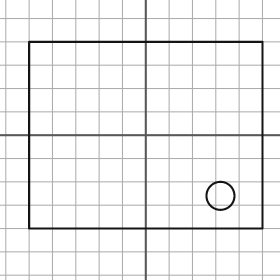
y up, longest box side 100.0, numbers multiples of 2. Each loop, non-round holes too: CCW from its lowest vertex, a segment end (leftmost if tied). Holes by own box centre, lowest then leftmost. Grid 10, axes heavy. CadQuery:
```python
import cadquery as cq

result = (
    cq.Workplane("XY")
    .moveTo(-50.0, -40.0)
    .lineTo(50.0, -40.0)
    .lineTo(50.0, 40.0)
    .lineTo(-50.0, 40.0)
    .close()
    .moveTo(32.0, -26.0)
    .circle(6.0)
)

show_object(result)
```